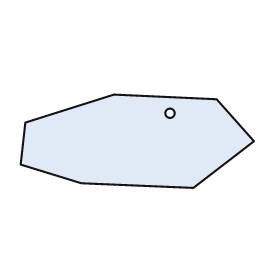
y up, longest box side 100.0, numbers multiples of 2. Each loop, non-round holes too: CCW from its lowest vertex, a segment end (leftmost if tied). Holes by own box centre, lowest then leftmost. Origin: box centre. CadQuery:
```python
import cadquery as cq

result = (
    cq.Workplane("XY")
    .moveTo(24.0, -20.0)
    .lineTo(50.0, 0.0)
    .lineTo(34.0, 18.0)
    .lineTo(-10.0, 20.0)
    .lineTo(-48.0, 8.0)
    .lineTo(-50.0, -10.0)
    .lineTo(-24.0, -18.0)
    .close()
    .moveTo(14.0, 12.0)
    .circle(2.0)
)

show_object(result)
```